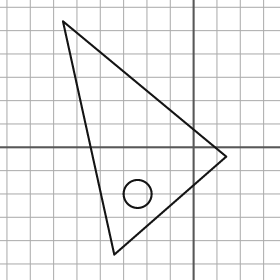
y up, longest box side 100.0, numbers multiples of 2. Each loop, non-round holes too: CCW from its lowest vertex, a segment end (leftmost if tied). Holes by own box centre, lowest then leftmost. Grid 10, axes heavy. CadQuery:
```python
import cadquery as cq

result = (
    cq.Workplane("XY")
    .moveTo(-34.0, -46.0)
    .lineTo(14.0, -4.0)
    .lineTo(-56.0, 54.0)
    .close()
    .moveTo(-24.0, -20.0)
    .circle(6.0)
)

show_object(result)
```